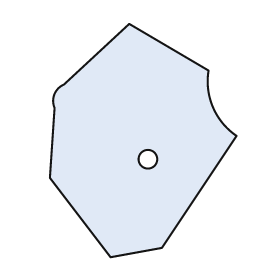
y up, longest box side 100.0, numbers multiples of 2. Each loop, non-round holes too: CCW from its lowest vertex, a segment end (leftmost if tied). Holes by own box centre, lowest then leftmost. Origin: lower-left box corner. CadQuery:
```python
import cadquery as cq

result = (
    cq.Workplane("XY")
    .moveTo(26.0, 0.0)
    .lineTo(48.0, 4.0)
    .lineTo(80.0, 52.0)
    .threePointArc((70.0, 64.0), (68.0, 80.0))
    .lineTo(34.0, 100.0)
    .lineTo(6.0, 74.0)
    .threePointArc((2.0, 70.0), (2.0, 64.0))
    .lineTo(0.0, 34.0)
    .close()
    .moveTo(42.0, 42.0)
    .circle(4.0)
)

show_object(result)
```